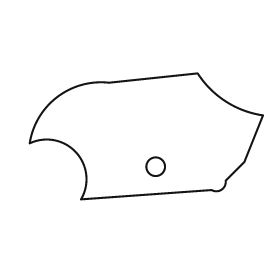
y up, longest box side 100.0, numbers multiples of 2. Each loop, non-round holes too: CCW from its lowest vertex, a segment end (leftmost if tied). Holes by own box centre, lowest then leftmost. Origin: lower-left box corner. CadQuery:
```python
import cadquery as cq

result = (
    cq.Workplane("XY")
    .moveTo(22.0, 0.0)
    .lineTo(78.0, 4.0)
    .threePointArc((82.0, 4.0), (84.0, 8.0))
    .lineTo(92.0, 16.0)
    .lineTo(100.0, 36.0)
    .threePointArc((84.0, 42.0), (72.0, 54.0))
    .lineTo(34.0, 50.0)
    .threePointArc((12.0, 44.0), (0.0, 24.0))
    .threePointArc((20.0, 20.0), (22.0, 0.0))
    .close()
    .moveTo(54.0, 14.0)
    .circle(4.0)
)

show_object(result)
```